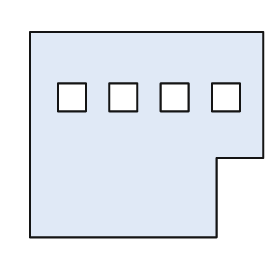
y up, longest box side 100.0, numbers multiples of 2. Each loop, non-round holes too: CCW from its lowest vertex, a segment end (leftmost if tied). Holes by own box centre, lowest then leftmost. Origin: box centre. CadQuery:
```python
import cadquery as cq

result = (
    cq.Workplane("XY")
    .moveTo(-50.0, -44.0)
    .lineTo(30.0, -44.0)
    .lineTo(30.0, -10.0)
    .lineTo(50.0, -10.0)
    .lineTo(50.0, 44.0)
    .lineTo(-50.0, 44.0)
    .close()
    .moveTo(-38.0, 10.0)
    .lineTo(-26.0, 10.0)
    .lineTo(-26.0, 22.0)
    .lineTo(-38.0, 22.0)
    .close()
    .moveTo(-16.0, 10.0)
    .lineTo(-4.0, 10.0)
    .lineTo(-4.0, 22.0)
    .lineTo(-16.0, 22.0)
    .close()
    .moveTo(6.0, 10.0)
    .lineTo(18.0, 10.0)
    .lineTo(18.0, 22.0)
    .lineTo(6.0, 22.0)
    .close()
    .moveTo(28.0, 10.0)
    .lineTo(40.0, 10.0)
    .lineTo(40.0, 22.0)
    .lineTo(28.0, 22.0)
    .close()
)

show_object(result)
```